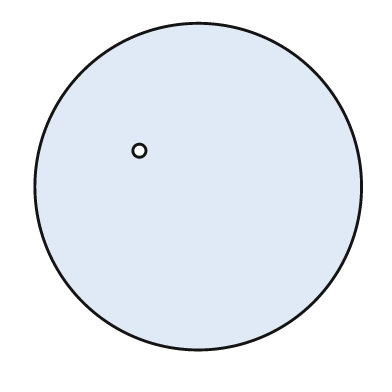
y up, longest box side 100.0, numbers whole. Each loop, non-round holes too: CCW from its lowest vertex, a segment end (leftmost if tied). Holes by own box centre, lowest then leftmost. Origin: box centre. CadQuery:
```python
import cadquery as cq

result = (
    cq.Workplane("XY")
    .moveTo(0.0, 0.0)
    .circle(50.0)
    .moveTo(-18.0, 11.0)
    .circle(2.0)
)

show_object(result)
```